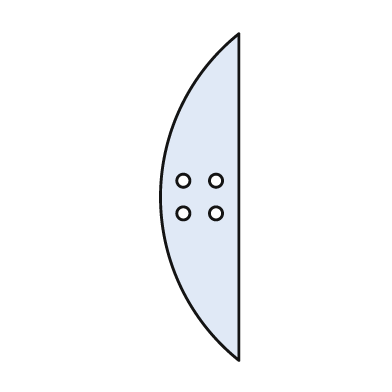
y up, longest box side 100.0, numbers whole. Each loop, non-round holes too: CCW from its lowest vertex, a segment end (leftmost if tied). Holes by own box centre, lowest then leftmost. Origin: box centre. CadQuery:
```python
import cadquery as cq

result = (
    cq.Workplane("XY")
    .moveTo(12.0, -50.0)
    .lineTo(12.0, 50.0)
    .threePointArc((-12.0, 0.0), (12.0, -50.0))
    .close()
    .moveTo(-5.0, -5.0)
    .circle(2.0)
    .moveTo(5.0, -5.0)
    .circle(2.0)
    .moveTo(-5.0, 5.0)
    .circle(2.0)
    .moveTo(5.0, 5.0)
    .circle(2.0)
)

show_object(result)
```